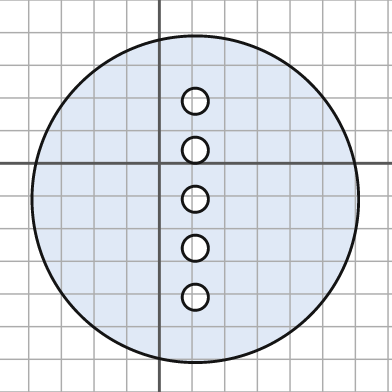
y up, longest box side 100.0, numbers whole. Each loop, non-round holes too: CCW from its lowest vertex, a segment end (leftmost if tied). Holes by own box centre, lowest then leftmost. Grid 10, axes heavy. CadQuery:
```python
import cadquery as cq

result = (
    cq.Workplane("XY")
    .moveTo(11.0, -11.0)
    .circle(50.0)
    .moveTo(11.0, -41.0)
    .circle(4.0)
    .moveTo(11.0, -26.0)
    .circle(4.0)
    .moveTo(11.0, -11.0)
    .circle(4.0)
    .moveTo(11.0, 4.0)
    .circle(4.0)
    .moveTo(11.0, 19.0)
    .circle(4.0)
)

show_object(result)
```